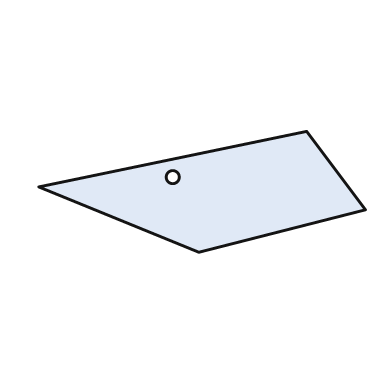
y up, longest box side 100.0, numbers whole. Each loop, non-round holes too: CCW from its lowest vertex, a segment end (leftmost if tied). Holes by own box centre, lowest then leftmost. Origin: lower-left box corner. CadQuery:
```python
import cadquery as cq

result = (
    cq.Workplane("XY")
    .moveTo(49.0, 0.0)
    .lineTo(100.0, 13.0)
    .lineTo(82.0, 37.0)
    .lineTo(0.0, 20.0)
    .close()
    .moveTo(41.0, 23.0)
    .circle(2.0)
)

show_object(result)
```